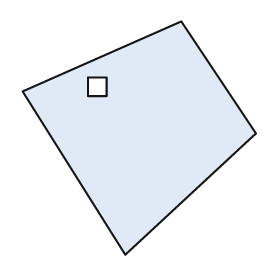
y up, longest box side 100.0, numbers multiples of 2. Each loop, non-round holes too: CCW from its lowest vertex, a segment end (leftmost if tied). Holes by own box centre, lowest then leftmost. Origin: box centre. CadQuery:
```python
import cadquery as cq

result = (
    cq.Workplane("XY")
    .moveTo(-6.0, -50.0)
    .lineTo(50.0, 2.0)
    .lineTo(18.0, 50.0)
    .lineTo(-50.0, 20.0)
    .close()
    .moveTo(-22.0, 18.0)
    .lineTo(-14.0, 18.0)
    .lineTo(-14.0, 26.0)
    .lineTo(-22.0, 26.0)
    .close()
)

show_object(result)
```